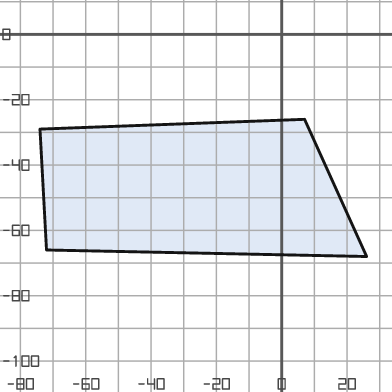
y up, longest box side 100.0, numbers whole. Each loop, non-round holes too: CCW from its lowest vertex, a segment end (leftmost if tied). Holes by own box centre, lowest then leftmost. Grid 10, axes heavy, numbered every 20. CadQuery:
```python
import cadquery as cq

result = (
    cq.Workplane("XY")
    .moveTo(26.0, -68.0)
    .lineTo(7.0, -26.0)
    .lineTo(-74.0, -29.0)
    .lineTo(-72.0, -66.0)
    .close()
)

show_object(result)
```